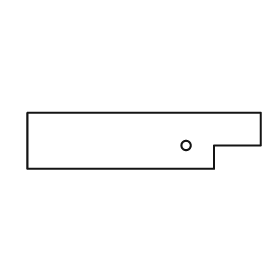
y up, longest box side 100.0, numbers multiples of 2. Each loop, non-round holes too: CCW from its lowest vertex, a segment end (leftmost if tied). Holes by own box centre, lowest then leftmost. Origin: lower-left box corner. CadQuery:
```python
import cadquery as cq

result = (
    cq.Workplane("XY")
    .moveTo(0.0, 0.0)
    .lineTo(80.0, 0.0)
    .lineTo(80.0, 10.0)
    .lineTo(100.0, 10.0)
    .lineTo(100.0, 24.0)
    .lineTo(0.0, 24.0)
    .close()
    .moveTo(68.0, 10.0)
    .circle(2.0)
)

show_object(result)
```